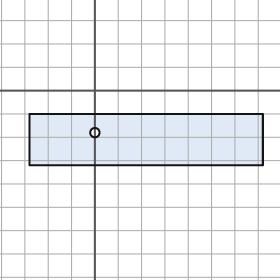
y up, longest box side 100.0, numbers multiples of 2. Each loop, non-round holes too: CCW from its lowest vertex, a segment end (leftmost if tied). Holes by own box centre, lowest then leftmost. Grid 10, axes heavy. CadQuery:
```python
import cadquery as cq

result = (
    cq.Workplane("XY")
    .moveTo(-28.0, -32.0)
    .lineTo(72.0, -32.0)
    .lineTo(72.0, -10.0)
    .lineTo(-28.0, -10.0)
    .close()
    .moveTo(0.0, -18.0)
    .circle(2.0)
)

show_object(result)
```